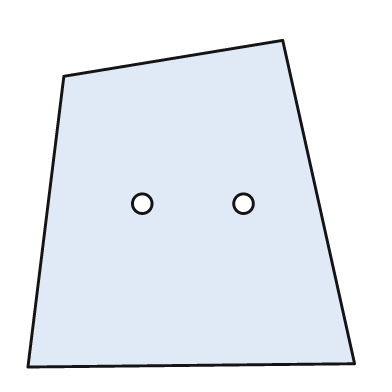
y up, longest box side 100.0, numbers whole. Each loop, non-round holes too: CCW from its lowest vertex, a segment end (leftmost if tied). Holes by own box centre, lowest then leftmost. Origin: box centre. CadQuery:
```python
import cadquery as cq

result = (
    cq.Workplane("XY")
    .moveTo(-50.0, -50.0)
    .lineTo(50.0, -49.0)
    .lineTo(28.0, 50.0)
    .lineTo(-39.0, 39.0)
    .close()
    .moveTo(-15.0, 0.0)
    .circle(3.0)
    .moveTo(16.0, 0.0)
    .circle(3.0)
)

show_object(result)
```